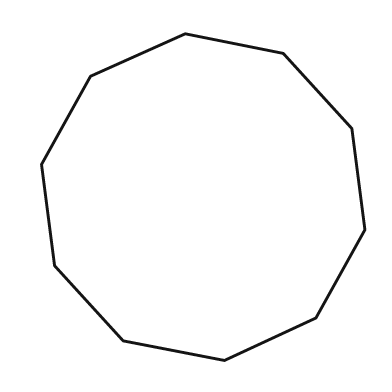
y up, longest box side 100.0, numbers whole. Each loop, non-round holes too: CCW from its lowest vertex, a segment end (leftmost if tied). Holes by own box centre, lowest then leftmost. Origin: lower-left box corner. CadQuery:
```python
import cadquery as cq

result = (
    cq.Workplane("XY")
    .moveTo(56.0, 0.0)
    .lineTo(84.0, 13.0)
    .lineTo(99.0, 40.0)
    .lineTo(95.0, 71.0)
    .lineTo(74.0, 94.0)
    .lineTo(44.0, 100.0)
    .lineTo(15.0, 87.0)
    .lineTo(0.0, 60.0)
    .lineTo(4.0, 29.0)
    .lineTo(25.0, 6.0)
    .close()
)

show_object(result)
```